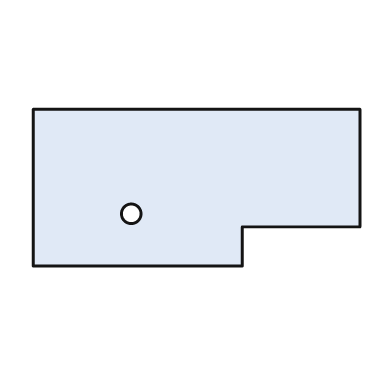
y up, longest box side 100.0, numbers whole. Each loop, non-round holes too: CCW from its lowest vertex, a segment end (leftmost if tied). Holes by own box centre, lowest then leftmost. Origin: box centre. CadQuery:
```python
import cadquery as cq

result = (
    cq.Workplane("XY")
    .moveTo(-50.0, -24.0)
    .lineTo(14.0, -24.0)
    .lineTo(14.0, -12.0)
    .lineTo(50.0, -12.0)
    .lineTo(50.0, 24.0)
    .lineTo(-50.0, 24.0)
    .close()
    .moveTo(-20.0, -8.0)
    .circle(3.0)
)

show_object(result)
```